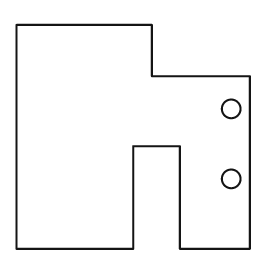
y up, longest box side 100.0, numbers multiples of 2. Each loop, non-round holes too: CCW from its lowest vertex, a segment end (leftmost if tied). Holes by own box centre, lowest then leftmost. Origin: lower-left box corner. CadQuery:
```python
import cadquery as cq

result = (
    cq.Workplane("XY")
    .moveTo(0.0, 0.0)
    .lineTo(50.0, 0.0)
    .lineTo(50.0, 44.0)
    .lineTo(70.0, 44.0)
    .lineTo(70.0, 0.0)
    .lineTo(100.0, 0.0)
    .lineTo(100.0, 74.0)
    .lineTo(58.0, 74.0)
    .lineTo(58.0, 96.0)
    .lineTo(0.0, 96.0)
    .close()
    .moveTo(92.0, 30.0)
    .circle(4.0)
    .moveTo(92.0, 60.0)
    .circle(4.0)
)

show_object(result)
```